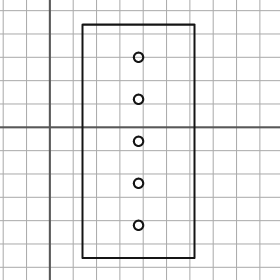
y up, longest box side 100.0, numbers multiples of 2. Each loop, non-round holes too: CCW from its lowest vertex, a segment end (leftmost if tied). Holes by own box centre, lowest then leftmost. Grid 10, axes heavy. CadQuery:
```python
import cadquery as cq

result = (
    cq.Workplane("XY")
    .moveTo(14.0, -56.0)
    .lineTo(62.0, -56.0)
    .lineTo(62.0, 44.0)
    .lineTo(14.0, 44.0)
    .close()
    .moveTo(38.0, -42.0)
    .circle(2.0)
    .moveTo(38.0, -24.0)
    .circle(2.0)
    .moveTo(38.0, -6.0)
    .circle(2.0)
    .moveTo(38.0, 12.0)
    .circle(2.0)
    .moveTo(38.0, 30.0)
    .circle(2.0)
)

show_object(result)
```